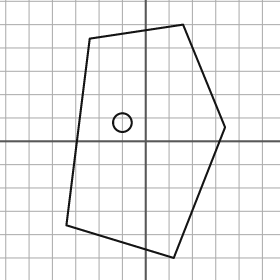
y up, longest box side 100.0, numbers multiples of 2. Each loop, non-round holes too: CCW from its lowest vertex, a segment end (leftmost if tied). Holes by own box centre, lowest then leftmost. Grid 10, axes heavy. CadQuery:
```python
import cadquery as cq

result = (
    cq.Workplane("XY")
    .moveTo(12.0, -50.0)
    .lineTo(34.0, 6.0)
    .lineTo(16.0, 50.0)
    .lineTo(-24.0, 44.0)
    .lineTo(-34.0, -36.0)
    .close()
    .moveTo(-10.0, 8.0)
    .circle(4.0)
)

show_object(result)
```